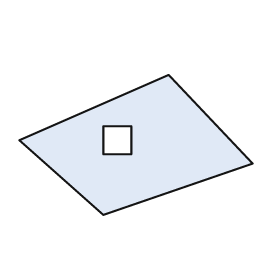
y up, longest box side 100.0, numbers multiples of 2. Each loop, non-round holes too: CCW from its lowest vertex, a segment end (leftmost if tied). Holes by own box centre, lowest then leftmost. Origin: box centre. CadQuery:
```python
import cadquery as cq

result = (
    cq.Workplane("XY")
    .moveTo(-14.0, -30.0)
    .lineTo(50.0, -8.0)
    .lineTo(14.0, 30.0)
    .lineTo(-50.0, 2.0)
    .close()
    .moveTo(-14.0, -4.0)
    .lineTo(-2.0, -4.0)
    .lineTo(-2.0, 8.0)
    .lineTo(-14.0, 8.0)
    .close()
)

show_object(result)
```